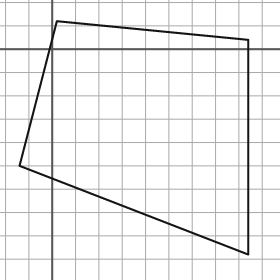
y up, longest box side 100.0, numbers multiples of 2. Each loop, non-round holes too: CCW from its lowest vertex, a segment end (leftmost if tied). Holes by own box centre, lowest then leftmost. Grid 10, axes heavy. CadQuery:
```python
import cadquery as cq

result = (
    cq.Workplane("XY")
    .moveTo(84.0, -88.0)
    .lineTo(84.0, 4.0)
    .lineTo(2.0, 12.0)
    .lineTo(-14.0, -50.0)
    .close()
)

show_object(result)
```